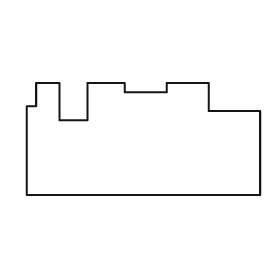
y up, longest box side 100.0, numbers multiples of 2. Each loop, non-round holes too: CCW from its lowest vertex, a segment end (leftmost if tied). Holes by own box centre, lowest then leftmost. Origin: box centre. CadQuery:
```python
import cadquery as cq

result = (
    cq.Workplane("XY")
    .moveTo(-50.0, -24.0)
    .lineTo(50.0, -24.0)
    .lineTo(50.0, 12.0)
    .lineTo(28.0, 12.0)
    .lineTo(28.0, 24.0)
    .lineTo(10.0, 24.0)
    .lineTo(10.0, 20.0)
    .lineTo(-8.0, 20.0)
    .lineTo(-8.0, 24.0)
    .lineTo(-24.0, 24.0)
    .lineTo(-24.0, 8.0)
    .lineTo(-36.0, 8.0)
    .lineTo(-36.0, 24.0)
    .lineTo(-46.0, 24.0)
    .lineTo(-46.0, 14.0)
    .lineTo(-50.0, 14.0)
    .close()
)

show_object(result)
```